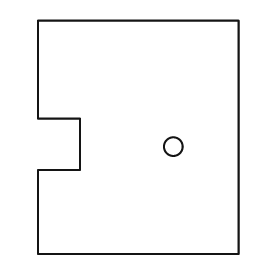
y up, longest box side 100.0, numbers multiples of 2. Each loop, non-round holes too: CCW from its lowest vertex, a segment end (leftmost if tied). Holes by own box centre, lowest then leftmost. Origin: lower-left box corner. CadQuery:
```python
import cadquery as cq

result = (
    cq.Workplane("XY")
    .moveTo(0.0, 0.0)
    .lineTo(86.0, 0.0)
    .lineTo(86.0, 100.0)
    .lineTo(0.0, 100.0)
    .lineTo(0.0, 58.0)
    .lineTo(18.0, 58.0)
    .lineTo(18.0, 36.0)
    .lineTo(0.0, 36.0)
    .close()
    .moveTo(58.0, 46.0)
    .circle(4.0)
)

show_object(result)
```